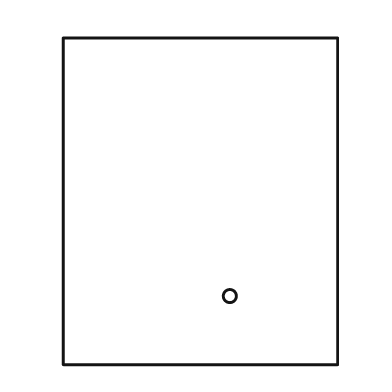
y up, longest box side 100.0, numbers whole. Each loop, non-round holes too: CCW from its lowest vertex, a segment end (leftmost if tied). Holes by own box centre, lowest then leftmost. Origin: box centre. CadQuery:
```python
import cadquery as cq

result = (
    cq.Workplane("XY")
    .moveTo(-42.0, -50.0)
    .lineTo(42.0, -50.0)
    .lineTo(42.0, 50.0)
    .lineTo(-42.0, 50.0)
    .close()
    .moveTo(9.0, -29.0)
    .circle(2.0)
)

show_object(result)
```